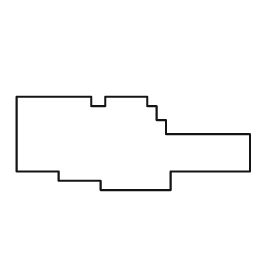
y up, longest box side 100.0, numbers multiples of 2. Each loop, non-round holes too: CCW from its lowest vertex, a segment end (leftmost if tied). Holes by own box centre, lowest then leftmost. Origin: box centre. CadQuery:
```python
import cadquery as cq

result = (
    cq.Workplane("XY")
    .moveTo(-14.0, -20.0)
    .lineTo(16.0, -20.0)
    .lineTo(16.0, -12.0)
    .lineTo(50.0, -12.0)
    .lineTo(50.0, 4.0)
    .lineTo(14.0, 4.0)
    .lineTo(14.0, 10.0)
    .lineTo(10.0, 10.0)
    .lineTo(10.0, 16.0)
    .lineTo(6.0, 16.0)
    .lineTo(6.0, 20.0)
    .lineTo(-12.0, 20.0)
    .lineTo(-12.0, 16.0)
    .lineTo(-18.0, 16.0)
    .lineTo(-18.0, 20.0)
    .lineTo(-50.0, 20.0)
    .lineTo(-50.0, -12.0)
    .lineTo(-32.0, -12.0)
    .lineTo(-32.0, -16.0)
    .lineTo(-14.0, -16.0)
    .close()
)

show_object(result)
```